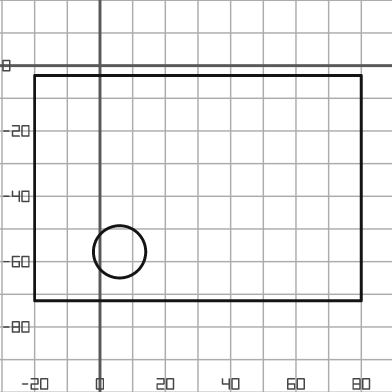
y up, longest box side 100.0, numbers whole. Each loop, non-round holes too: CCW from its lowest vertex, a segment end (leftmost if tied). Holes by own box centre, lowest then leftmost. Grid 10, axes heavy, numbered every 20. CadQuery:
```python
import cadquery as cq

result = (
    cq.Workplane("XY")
    .moveTo(-20.0, -72.0)
    .lineTo(80.0, -72.0)
    .lineTo(80.0, -3.0)
    .lineTo(-20.0, -3.0)
    .close()
    .moveTo(6.0, -57.0)
    .circle(8.0)
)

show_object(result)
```